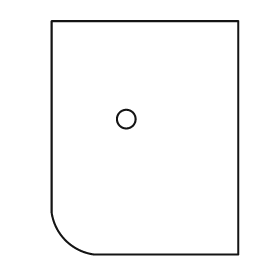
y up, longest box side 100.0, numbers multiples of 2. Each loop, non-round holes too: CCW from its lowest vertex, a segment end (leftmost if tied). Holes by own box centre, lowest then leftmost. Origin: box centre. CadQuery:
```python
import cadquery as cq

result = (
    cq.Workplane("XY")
    .moveTo(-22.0, -50.0)
    .lineTo(40.0, -50.0)
    .lineTo(40.0, 50.0)
    .lineTo(-40.0, 50.0)
    .lineTo(-40.0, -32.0)
    .threePointArc((-34.0, -44.0), (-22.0, -50.0))
    .close()
    .moveTo(-8.0, 8.0)
    .circle(4.0)
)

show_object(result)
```